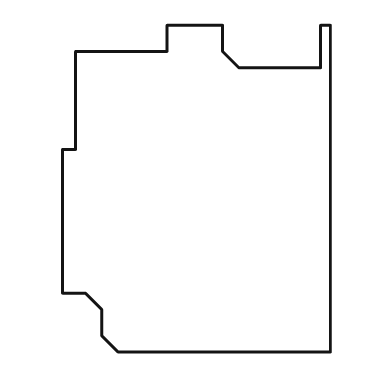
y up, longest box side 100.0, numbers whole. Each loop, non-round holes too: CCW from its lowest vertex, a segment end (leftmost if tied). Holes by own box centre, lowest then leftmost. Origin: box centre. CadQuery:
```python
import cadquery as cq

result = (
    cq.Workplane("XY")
    .moveTo(-24.0, -50.0)
    .lineTo(41.0, -50.0)
    .lineTo(41.0, 50.0)
    .lineTo(38.0, 50.0)
    .lineTo(38.0, 37.0)
    .lineTo(13.0, 37.0)
    .lineTo(8.0, 42.0)
    .lineTo(8.0, 50.0)
    .lineTo(-9.0, 50.0)
    .lineTo(-9.0, 42.0)
    .lineTo(-37.0, 42.0)
    .lineTo(-37.0, 12.0)
    .lineTo(-41.0, 12.0)
    .lineTo(-41.0, -32.0)
    .lineTo(-34.0, -32.0)
    .lineTo(-29.0, -37.0)
    .lineTo(-29.0, -45.0)
    .close()
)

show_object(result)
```